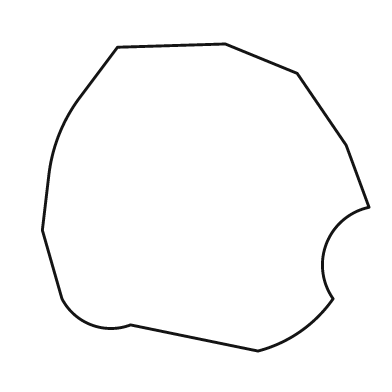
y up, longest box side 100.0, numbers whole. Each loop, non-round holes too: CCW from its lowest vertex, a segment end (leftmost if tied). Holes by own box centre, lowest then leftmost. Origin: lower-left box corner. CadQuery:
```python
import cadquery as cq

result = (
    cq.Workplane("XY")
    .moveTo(66.0, 0.0)
    .threePointArc((79.0, 6.0), (89.0, 16.0))
    .threePointArc((87.0, 33.0), (100.0, 44.0))
    .lineTo(93.0, 63.0)
    .lineTo(78.0, 85.0)
    .lineTo(56.0, 94.0)
    .lineTo(23.0, 93.0)
    .lineTo(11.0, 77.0)
    .threePointArc((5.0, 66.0), (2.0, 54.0))
    .lineTo(0.0, 37.0)
    .lineTo(6.0, 16.0)
    .threePointArc((15.0, 8.0), (27.0, 8.0))
    .close()
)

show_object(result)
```